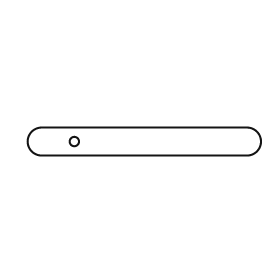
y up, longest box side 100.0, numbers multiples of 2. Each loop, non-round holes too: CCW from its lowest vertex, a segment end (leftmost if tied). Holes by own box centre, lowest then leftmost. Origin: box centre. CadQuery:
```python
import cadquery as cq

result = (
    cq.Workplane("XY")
    .moveTo(-44.0, -6.0)
    .lineTo(44.0, -6.0)
    .threePointArc((50.0, 0.0), (44.0, 6.0))
    .lineTo(-44.0, 6.0)
    .threePointArc((-50.0, 0.0), (-44.0, -6.0))
    .close()
    .moveTo(-30.0, 0.0)
    .circle(2.0)
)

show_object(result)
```